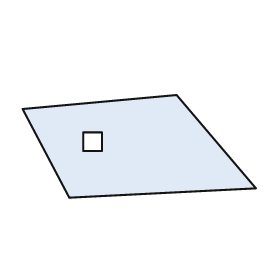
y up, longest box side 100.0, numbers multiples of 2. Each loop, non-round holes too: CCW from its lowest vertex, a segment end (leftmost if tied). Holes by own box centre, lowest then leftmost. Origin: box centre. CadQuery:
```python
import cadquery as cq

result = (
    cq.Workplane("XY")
    .moveTo(-30.0, -22.0)
    .lineTo(50.0, -18.0)
    .lineTo(16.0, 22.0)
    .lineTo(-50.0, 16.0)
    .close()
    .moveTo(-24.0, -2.0)
    .lineTo(-16.0, -2.0)
    .lineTo(-16.0, 6.0)
    .lineTo(-24.0, 6.0)
    .close()
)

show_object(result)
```